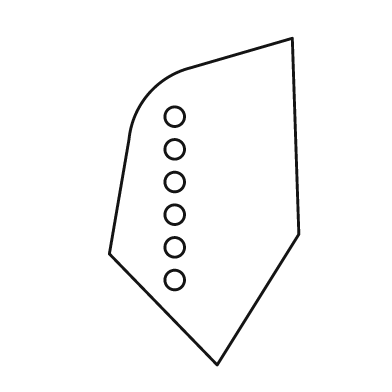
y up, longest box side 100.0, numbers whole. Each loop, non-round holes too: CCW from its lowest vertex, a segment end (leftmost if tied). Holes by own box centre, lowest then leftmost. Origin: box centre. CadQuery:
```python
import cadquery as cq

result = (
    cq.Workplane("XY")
    .moveTo(4.0, -50.0)
    .lineTo(29.0, -10.0)
    .lineTo(27.0, 50.0)
    .lineTo(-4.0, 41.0)
    .threePointArc((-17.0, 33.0), (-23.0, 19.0))
    .lineTo(-29.0, -16.0)
    .close()
    .moveTo(-9.0, -24.0)
    .circle(3.0)
    .moveTo(-9.0, -14.0)
    .circle(3.0)
    .moveTo(-9.0, -4.0)
    .circle(3.0)
    .moveTo(-9.0, 6.0)
    .circle(3.0)
    .moveTo(-9.0, 16.0)
    .circle(3.0)
    .moveTo(-9.0, 26.0)
    .circle(3.0)
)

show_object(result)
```